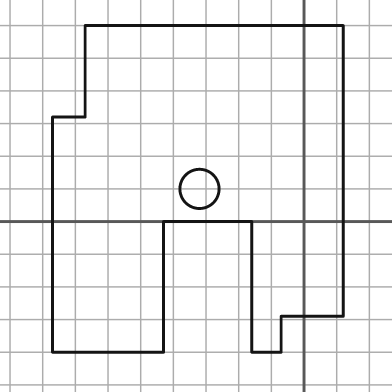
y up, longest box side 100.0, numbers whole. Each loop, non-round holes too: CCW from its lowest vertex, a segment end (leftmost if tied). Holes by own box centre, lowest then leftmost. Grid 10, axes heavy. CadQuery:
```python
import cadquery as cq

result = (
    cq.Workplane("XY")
    .moveTo(-77.0, -40.0)
    .lineTo(-43.0, -40.0)
    .lineTo(-43.0, 0.0)
    .lineTo(-16.0, 0.0)
    .lineTo(-16.0, -40.0)
    .lineTo(-7.0, -40.0)
    .lineTo(-7.0, -29.0)
    .lineTo(12.0, -29.0)
    .lineTo(12.0, 60.0)
    .lineTo(-67.0, 60.0)
    .lineTo(-67.0, 32.0)
    .lineTo(-77.0, 32.0)
    .close()
    .moveTo(-32.0, 10.0)
    .circle(6.0)
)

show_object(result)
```